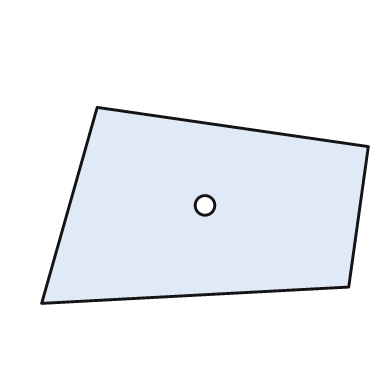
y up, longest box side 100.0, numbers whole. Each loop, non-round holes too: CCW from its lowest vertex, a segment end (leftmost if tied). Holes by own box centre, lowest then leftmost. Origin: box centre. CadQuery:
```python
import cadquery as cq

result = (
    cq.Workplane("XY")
    .moveTo(-50.0, -30.0)
    .lineTo(44.0, -25.0)
    .lineTo(50.0, 18.0)
    .lineTo(-33.0, 30.0)
    .close()
    .moveTo(0.0, 0.0)
    .circle(3.0)
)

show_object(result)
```